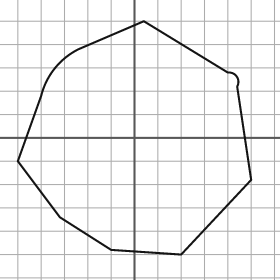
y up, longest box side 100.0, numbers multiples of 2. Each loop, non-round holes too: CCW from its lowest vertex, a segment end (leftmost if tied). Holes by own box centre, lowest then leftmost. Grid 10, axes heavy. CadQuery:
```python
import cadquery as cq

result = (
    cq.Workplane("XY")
    .moveTo(20.0, -50.0)
    .lineTo(50.0, -18.0)
    .lineTo(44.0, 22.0)
    .threePointArc((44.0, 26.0), (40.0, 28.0))
    .lineTo(4.0, 50.0)
    .lineTo(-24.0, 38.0)
    .threePointArc((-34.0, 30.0), (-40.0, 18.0))
    .lineTo(-50.0, -10.0)
    .lineTo(-32.0, -34.0)
    .lineTo(-10.0, -48.0)
    .close()
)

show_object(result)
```